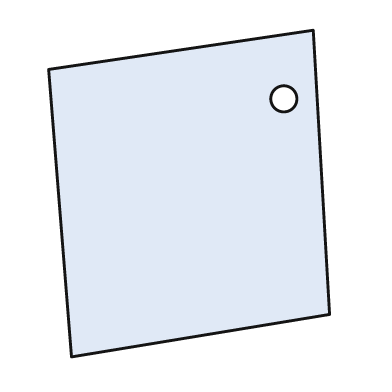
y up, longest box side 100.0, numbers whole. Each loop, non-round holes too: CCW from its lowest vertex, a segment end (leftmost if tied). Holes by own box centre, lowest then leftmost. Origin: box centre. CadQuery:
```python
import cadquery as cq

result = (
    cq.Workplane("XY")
    .moveTo(-36.0, -50.0)
    .lineTo(43.0, -37.0)
    .lineTo(38.0, 50.0)
    .lineTo(-43.0, 38.0)
    .close()
    .moveTo(29.0, 29.0)
    .circle(4.0)
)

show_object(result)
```